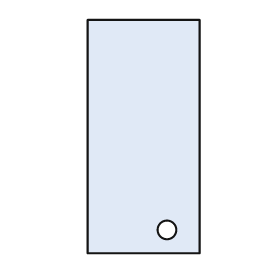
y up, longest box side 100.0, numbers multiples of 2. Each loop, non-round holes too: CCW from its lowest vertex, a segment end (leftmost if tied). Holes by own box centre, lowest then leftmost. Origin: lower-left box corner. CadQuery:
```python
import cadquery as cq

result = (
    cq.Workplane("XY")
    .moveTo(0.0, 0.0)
    .lineTo(48.0, 0.0)
    .lineTo(48.0, 100.0)
    .lineTo(0.0, 100.0)
    .close()
    .moveTo(34.0, 10.0)
    .circle(4.0)
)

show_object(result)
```